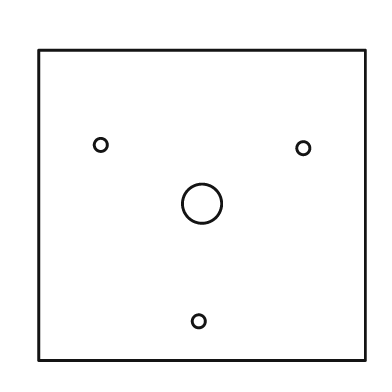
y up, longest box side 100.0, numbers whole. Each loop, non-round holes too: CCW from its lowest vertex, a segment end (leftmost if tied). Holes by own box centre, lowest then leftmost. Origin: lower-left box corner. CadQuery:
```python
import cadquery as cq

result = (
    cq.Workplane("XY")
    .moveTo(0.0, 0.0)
    .lineTo(100.0, 0.0)
    .lineTo(100.0, 95.0)
    .lineTo(0.0, 95.0)
    .close()
    .moveTo(49.0, 12.0)
    .circle(2.0)
    .moveTo(50.0, 48.0)
    .circle(6.0)
    .moveTo(81.0, 65.0)
    .circle(2.0)
    .moveTo(19.0, 66.0)
    .circle(2.0)
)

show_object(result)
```